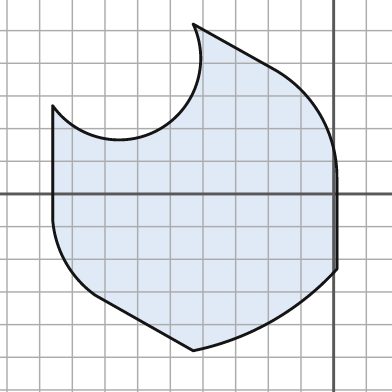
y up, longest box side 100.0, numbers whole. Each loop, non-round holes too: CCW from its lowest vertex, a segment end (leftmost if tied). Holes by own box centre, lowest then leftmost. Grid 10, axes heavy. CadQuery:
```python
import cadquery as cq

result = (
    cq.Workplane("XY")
    .moveTo(-43.0, -48.0)
    .threePointArc((-19.0, -39.0), (1.0, -23.0))
    .lineTo(1.0, 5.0)
    .threePointArc((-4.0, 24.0), (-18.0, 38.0))
    .lineTo(-43.0, 52.0)
    .threePointArc((-53.0, 20.0), (-86.0, 27.0))
    .lineTo(-86.0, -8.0)
    .threePointArc((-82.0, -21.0), (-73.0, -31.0))
    .close()
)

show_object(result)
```